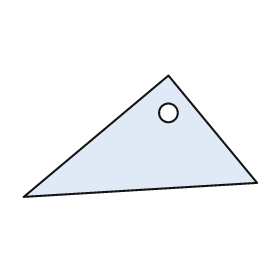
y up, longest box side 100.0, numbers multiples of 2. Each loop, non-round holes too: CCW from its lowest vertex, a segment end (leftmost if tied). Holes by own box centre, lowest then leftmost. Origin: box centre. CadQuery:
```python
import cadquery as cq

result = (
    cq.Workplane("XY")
    .moveTo(-50.0, -26.0)
    .lineTo(50.0, -20.0)
    .lineTo(12.0, 26.0)
    .close()
    .moveTo(12.0, 10.0)
    .circle(4.0)
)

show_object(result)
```